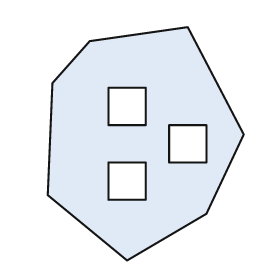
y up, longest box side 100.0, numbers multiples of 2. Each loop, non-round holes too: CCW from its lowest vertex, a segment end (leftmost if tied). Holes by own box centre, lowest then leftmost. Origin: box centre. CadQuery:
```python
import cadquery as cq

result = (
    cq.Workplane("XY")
    .moveTo(-8.0, -50.0)
    .lineTo(26.0, -30.0)
    .lineTo(42.0, 4.0)
    .lineTo(18.0, 50.0)
    .lineTo(-24.0, 44.0)
    .lineTo(-40.0, 26.0)
    .lineTo(-42.0, -22.0)
    .close()
    .moveTo(-16.0, -24.0)
    .lineTo(0.0, -24.0)
    .lineTo(0.0, -8.0)
    .lineTo(-16.0, -8.0)
    .close()
    .moveTo(10.0, -8.0)
    .lineTo(26.0, -8.0)
    .lineTo(26.0, 8.0)
    .lineTo(10.0, 8.0)
    .close()
    .moveTo(-16.0, 8.0)
    .lineTo(0.0, 8.0)
    .lineTo(0.0, 24.0)
    .lineTo(-16.0, 24.0)
    .close()
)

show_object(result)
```